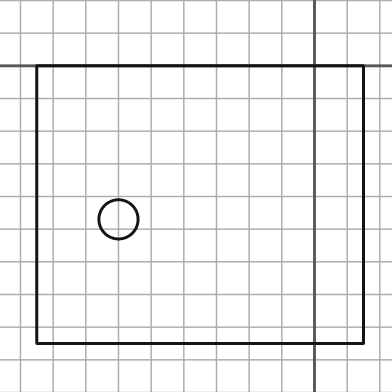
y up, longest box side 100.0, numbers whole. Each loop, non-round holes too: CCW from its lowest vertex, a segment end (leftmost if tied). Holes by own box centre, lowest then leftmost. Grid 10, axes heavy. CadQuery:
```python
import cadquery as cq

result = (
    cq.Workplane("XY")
    .moveTo(-85.0, -85.0)
    .lineTo(15.0, -85.0)
    .lineTo(15.0, 0.0)
    .lineTo(-85.0, 0.0)
    .close()
    .moveTo(-60.0, -47.0)
    .circle(6.0)
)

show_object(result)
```